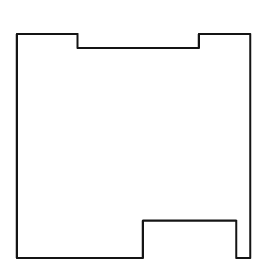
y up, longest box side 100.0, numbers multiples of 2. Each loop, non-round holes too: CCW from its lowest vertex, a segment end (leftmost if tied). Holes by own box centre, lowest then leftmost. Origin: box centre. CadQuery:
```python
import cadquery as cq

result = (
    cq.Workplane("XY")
    .moveTo(-50.0, -48.0)
    .lineTo(4.0, -48.0)
    .lineTo(4.0, -32.0)
    .lineTo(44.0, -32.0)
    .lineTo(44.0, -48.0)
    .lineTo(50.0, -48.0)
    .lineTo(50.0, 48.0)
    .lineTo(28.0, 48.0)
    .lineTo(28.0, 42.0)
    .lineTo(-24.0, 42.0)
    .lineTo(-24.0, 48.0)
    .lineTo(-50.0, 48.0)
    .close()
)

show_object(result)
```